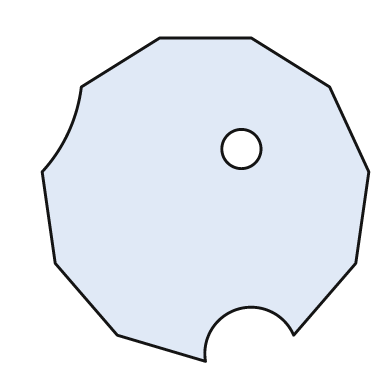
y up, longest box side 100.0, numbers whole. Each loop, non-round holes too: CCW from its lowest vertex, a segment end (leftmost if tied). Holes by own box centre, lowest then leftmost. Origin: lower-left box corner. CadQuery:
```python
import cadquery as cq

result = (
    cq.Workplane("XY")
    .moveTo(50.0, 0.0)
    .threePointArc((60.0, 16.0), (77.0, 8.0))
    .lineTo(96.0, 30.0)
    .lineTo(100.0, 58.0)
    .lineTo(88.0, 84.0)
    .lineTo(64.0, 99.0)
    .lineTo(36.0, 99.0)
    .lineTo(12.0, 84.0)
    .threePointArc((8.0, 70.0), (0.0, 58.0))
    .lineTo(4.0, 30.0)
    .lineTo(23.0, 8.0)
    .close()
    .moveTo(61.0, 65.0)
    .circle(6.0)
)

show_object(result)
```